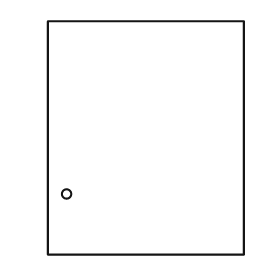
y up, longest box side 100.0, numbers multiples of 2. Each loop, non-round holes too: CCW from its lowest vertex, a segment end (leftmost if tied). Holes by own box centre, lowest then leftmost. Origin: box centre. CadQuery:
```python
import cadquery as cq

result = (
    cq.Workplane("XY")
    .moveTo(-42.0, -50.0)
    .lineTo(42.0, -50.0)
    .lineTo(42.0, 50.0)
    .lineTo(-42.0, 50.0)
    .close()
    .moveTo(-34.0, -24.0)
    .circle(2.0)
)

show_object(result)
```